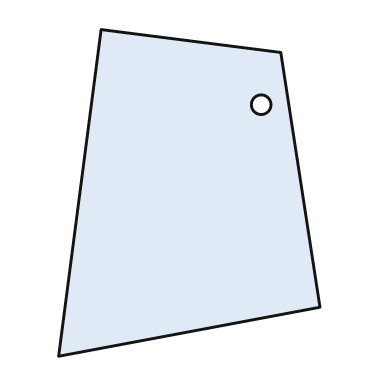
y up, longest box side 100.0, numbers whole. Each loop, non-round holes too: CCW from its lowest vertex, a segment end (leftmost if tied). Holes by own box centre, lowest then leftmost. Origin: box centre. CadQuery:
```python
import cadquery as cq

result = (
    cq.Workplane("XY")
    .moveTo(-40.0, -50.0)
    .lineTo(40.0, -35.0)
    .lineTo(28.0, 43.0)
    .lineTo(-27.0, 50.0)
    .close()
    .moveTo(22.0, 27.0)
    .circle(3.0)
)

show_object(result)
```